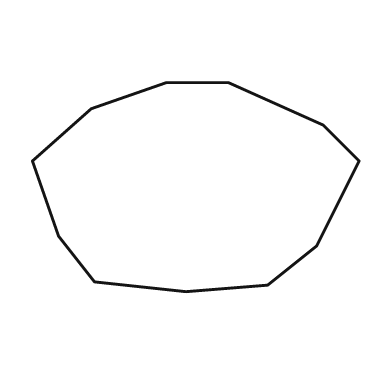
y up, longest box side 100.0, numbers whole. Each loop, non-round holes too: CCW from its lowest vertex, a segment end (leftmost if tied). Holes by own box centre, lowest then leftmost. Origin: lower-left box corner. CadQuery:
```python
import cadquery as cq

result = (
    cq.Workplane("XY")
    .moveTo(47.0, 0.0)
    .lineTo(72.0, 2.0)
    .lineTo(87.0, 14.0)
    .lineTo(100.0, 40.0)
    .lineTo(89.0, 51.0)
    .lineTo(60.0, 64.0)
    .lineTo(41.0, 64.0)
    .lineTo(18.0, 56.0)
    .lineTo(0.0, 40.0)
    .lineTo(8.0, 17.0)
    .lineTo(19.0, 3.0)
    .close()
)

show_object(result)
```